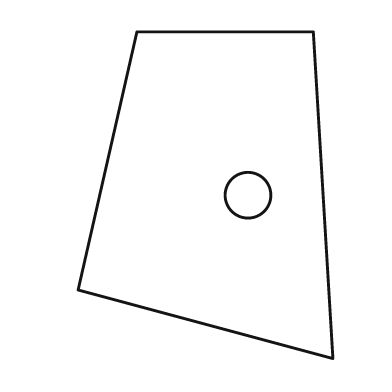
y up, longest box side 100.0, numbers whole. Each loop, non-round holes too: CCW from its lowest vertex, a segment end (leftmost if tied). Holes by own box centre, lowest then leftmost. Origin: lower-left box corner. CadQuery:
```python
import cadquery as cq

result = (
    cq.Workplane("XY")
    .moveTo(78.0, 0.0)
    .lineTo(72.0, 100.0)
    .lineTo(18.0, 100.0)
    .lineTo(0.0, 21.0)
    .close()
    .moveTo(52.0, 50.0)
    .circle(7.0)
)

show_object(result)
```